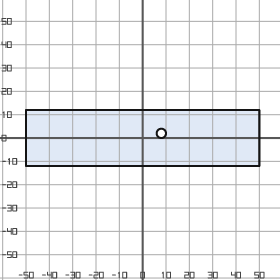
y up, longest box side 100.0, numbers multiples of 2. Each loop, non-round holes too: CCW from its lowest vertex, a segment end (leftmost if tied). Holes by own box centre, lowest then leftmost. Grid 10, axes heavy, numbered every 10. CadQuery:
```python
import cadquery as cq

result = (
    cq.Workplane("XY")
    .moveTo(-50.0, -12.0)
    .lineTo(50.0, -12.0)
    .lineTo(50.0, 12.0)
    .lineTo(-50.0, 12.0)
    .close()
    .moveTo(8.0, 2.0)
    .circle(2.0)
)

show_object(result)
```